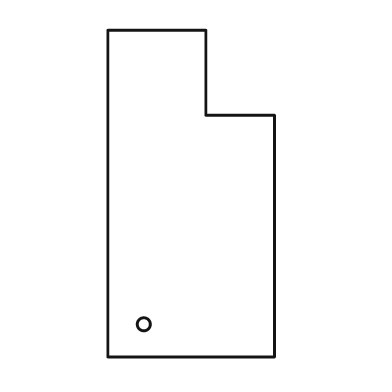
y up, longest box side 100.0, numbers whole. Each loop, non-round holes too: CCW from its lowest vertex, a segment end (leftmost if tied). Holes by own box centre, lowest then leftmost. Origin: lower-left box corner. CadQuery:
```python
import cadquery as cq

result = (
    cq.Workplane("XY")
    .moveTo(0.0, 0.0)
    .lineTo(51.0, 0.0)
    .lineTo(51.0, 74.0)
    .lineTo(30.0, 74.0)
    .lineTo(30.0, 100.0)
    .lineTo(0.0, 100.0)
    .close()
    .moveTo(11.0, 10.0)
    .circle(2.0)
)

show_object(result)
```